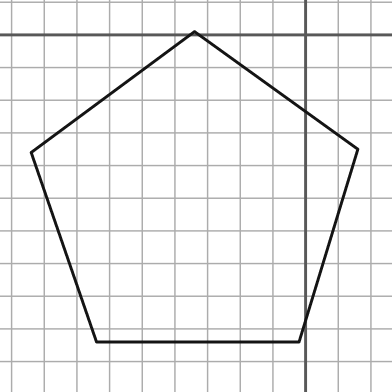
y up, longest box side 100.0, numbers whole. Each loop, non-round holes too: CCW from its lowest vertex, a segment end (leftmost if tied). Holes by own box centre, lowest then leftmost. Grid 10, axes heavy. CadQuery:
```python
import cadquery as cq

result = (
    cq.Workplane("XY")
    .moveTo(-64.0, -94.0)
    .lineTo(-2.0, -94.0)
    .lineTo(16.0, -35.0)
    .lineTo(-34.0, 1.0)
    .lineTo(-84.0, -36.0)
    .close()
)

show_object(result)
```